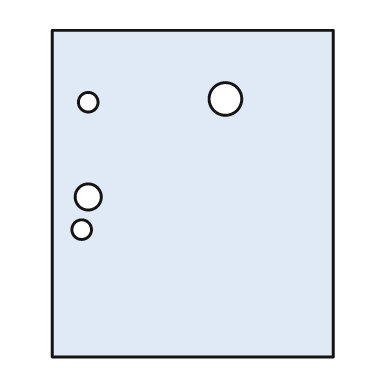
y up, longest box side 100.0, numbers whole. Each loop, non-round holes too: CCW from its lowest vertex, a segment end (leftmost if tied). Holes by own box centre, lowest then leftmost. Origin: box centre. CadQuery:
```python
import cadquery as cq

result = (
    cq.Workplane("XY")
    .moveTo(-43.0, -50.0)
    .lineTo(43.0, -50.0)
    .lineTo(43.0, 50.0)
    .lineTo(-43.0, 50.0)
    .close()
    .moveTo(-34.0, -11.0)
    .circle(3.0)
    .moveTo(-32.0, -1.0)
    .circle(4.0)
    .moveTo(-32.0, 28.0)
    .circle(3.0)
    .moveTo(10.0, 29.0)
    .circle(5.0)
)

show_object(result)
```